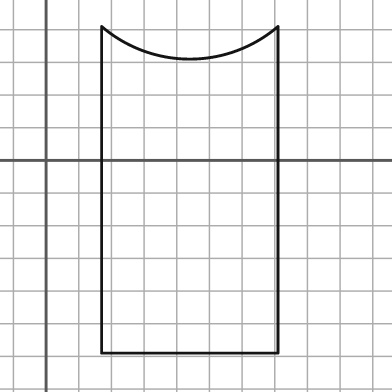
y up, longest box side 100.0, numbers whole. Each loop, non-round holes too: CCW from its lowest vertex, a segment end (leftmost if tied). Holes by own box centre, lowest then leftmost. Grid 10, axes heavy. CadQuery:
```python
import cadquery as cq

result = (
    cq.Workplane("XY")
    .moveTo(17.0, -59.0)
    .lineTo(71.0, -59.0)
    .lineTo(71.0, 41.0)
    .threePointArc((44.0, 31.0), (17.0, 41.0))
    .close()
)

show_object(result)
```